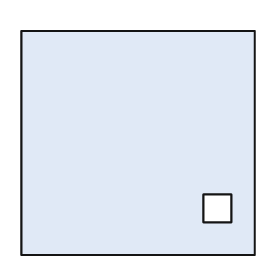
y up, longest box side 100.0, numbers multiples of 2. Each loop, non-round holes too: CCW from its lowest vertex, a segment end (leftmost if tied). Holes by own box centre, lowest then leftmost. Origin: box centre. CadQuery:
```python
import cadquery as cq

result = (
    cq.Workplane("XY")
    .moveTo(-50.0, -48.0)
    .lineTo(50.0, -48.0)
    .lineTo(50.0, 48.0)
    .lineTo(-50.0, 48.0)
    .close()
    .moveTo(28.0, -34.0)
    .lineTo(40.0, -34.0)
    .lineTo(40.0, -22.0)
    .lineTo(28.0, -22.0)
    .close()
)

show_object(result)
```